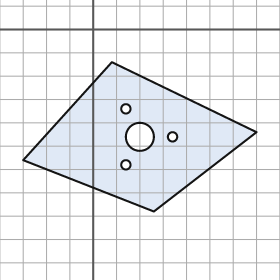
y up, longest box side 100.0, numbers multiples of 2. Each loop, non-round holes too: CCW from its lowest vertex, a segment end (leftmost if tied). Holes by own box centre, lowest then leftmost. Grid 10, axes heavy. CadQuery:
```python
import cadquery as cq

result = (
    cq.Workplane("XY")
    .moveTo(26.0, -78.0)
    .lineTo(70.0, -44.0)
    .lineTo(8.0, -14.0)
    .lineTo(-30.0, -56.0)
    .close()
    .moveTo(14.0, -58.0)
    .circle(2.0)
    .moveTo(20.0, -46.0)
    .circle(6.0)
    .moveTo(34.0, -46.0)
    .circle(2.0)
    .moveTo(14.0, -34.0)
    .circle(2.0)
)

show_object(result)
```